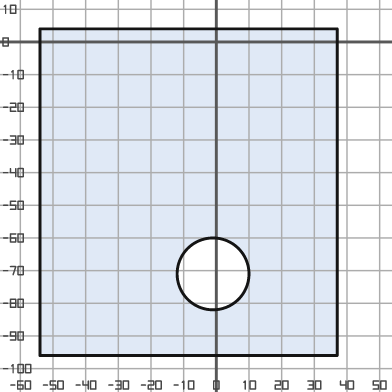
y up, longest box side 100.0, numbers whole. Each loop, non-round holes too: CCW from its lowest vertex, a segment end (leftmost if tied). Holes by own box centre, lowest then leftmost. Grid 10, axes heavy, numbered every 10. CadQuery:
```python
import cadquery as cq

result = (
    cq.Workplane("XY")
    .moveTo(-54.0, -96.0)
    .lineTo(37.0, -96.0)
    .lineTo(37.0, 4.0)
    .lineTo(-54.0, 4.0)
    .close()
    .moveTo(-1.0, -71.0)
    .circle(11.0)
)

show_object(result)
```